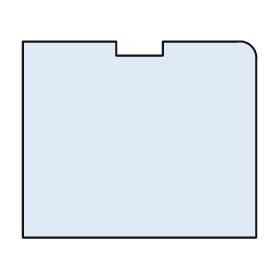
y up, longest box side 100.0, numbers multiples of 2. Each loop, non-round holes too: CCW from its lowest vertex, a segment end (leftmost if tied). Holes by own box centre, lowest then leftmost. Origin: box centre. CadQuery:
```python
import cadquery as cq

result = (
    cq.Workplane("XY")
    .moveTo(-50.0, -42.0)
    .lineTo(50.0, -42.0)
    .lineTo(50.0, 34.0)
    .threePointArc((48.0, 40.0), (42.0, 42.0))
    .lineTo(10.0, 42.0)
    .lineTo(10.0, 36.0)
    .lineTo(-10.0, 36.0)
    .lineTo(-10.0, 42.0)
    .lineTo(-50.0, 42.0)
    .close()
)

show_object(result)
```